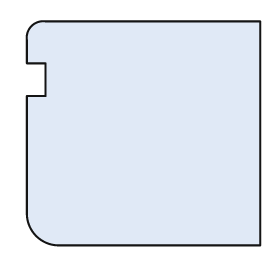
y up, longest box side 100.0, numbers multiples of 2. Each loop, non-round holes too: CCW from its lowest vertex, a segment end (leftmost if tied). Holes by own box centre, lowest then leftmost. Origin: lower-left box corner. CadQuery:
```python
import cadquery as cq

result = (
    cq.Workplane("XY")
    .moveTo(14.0, 0.0)
    .lineTo(100.0, 0.0)
    .lineTo(100.0, 96.0)
    .lineTo(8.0, 96.0)
    .threePointArc((2.0, 94.0), (0.0, 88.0))
    .lineTo(0.0, 78.0)
    .lineTo(8.0, 78.0)
    .lineTo(8.0, 64.0)
    .lineTo(0.0, 64.0)
    .lineTo(0.0, 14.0)
    .threePointArc((4.0, 4.0), (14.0, 0.0))
    .close()
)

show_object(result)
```